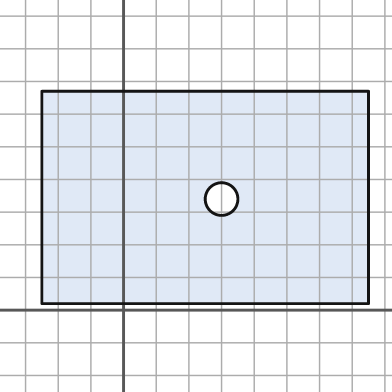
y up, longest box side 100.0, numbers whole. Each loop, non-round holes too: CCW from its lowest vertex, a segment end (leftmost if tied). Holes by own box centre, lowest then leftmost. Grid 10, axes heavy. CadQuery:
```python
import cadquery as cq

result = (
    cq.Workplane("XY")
    .moveTo(-25.0, 2.0)
    .lineTo(75.0, 2.0)
    .lineTo(75.0, 67.0)
    .lineTo(-25.0, 67.0)
    .close()
    .moveTo(30.0, 34.0)
    .circle(5.0)
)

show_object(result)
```